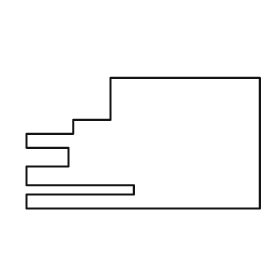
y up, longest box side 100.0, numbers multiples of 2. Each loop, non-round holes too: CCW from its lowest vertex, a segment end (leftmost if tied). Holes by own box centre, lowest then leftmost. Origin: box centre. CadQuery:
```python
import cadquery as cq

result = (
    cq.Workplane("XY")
    .moveTo(-50.0, -28.0)
    .lineTo(50.0, -28.0)
    .lineTo(50.0, 28.0)
    .lineTo(-14.0, 28.0)
    .lineTo(-14.0, 10.0)
    .lineTo(-30.0, 10.0)
    .lineTo(-30.0, 4.0)
    .lineTo(-50.0, 4.0)
    .lineTo(-50.0, -2.0)
    .lineTo(-32.0, -2.0)
    .lineTo(-32.0, -10.0)
    .lineTo(-50.0, -10.0)
    .lineTo(-50.0, -18.0)
    .lineTo(-4.0, -18.0)
    .lineTo(-4.0, -22.0)
    .lineTo(-50.0, -22.0)
    .close()
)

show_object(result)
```